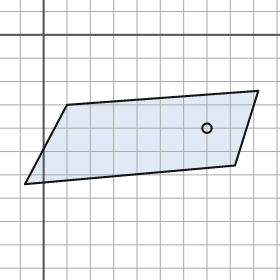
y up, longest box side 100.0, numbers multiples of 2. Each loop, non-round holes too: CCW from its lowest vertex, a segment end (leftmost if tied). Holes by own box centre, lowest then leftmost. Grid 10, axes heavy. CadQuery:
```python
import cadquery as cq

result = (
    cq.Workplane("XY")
    .moveTo(-8.0, -64.0)
    .lineTo(82.0, -56.0)
    .lineTo(92.0, -24.0)
    .lineTo(10.0, -30.0)
    .close()
    .moveTo(70.0, -40.0)
    .circle(2.0)
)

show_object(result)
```